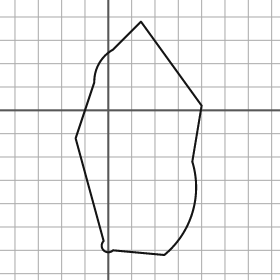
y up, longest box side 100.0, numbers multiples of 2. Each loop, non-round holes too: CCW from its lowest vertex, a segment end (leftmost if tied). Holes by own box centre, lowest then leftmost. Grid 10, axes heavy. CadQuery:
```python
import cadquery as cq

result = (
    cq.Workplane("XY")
    .moveTo(24.0, -62.0)
    .threePointArc((36.0, -44.0), (36.0, -22.0))
    .lineTo(40.0, 2.0)
    .lineTo(14.0, 38.0)
    .lineTo(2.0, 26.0)
    .threePointArc((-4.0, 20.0), (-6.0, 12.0))
    .lineTo(-14.0, -12.0)
    .lineTo(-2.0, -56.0)
    .threePointArc((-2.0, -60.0), (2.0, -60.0))
    .close()
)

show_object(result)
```